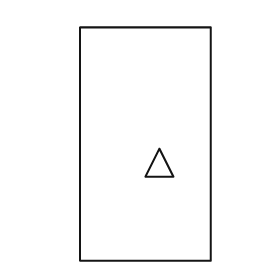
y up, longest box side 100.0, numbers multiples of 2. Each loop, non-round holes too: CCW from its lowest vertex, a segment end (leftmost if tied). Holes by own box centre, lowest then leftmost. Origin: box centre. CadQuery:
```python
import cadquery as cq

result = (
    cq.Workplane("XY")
    .moveTo(-28.0, -50.0)
    .lineTo(28.0, -50.0)
    .lineTo(28.0, 50.0)
    .lineTo(-28.0, 50.0)
    .close()
    .moveTo(0.0, -14.0)
    .lineTo(12.0, -14.0)
    .lineTo(6.0, -2.0)
    .close()
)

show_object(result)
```